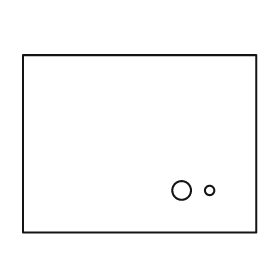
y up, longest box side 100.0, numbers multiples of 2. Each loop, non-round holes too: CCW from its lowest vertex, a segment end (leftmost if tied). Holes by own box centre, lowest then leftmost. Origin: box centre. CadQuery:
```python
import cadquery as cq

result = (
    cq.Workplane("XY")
    .moveTo(-50.0, -38.0)
    .lineTo(50.0, -38.0)
    .lineTo(50.0, 38.0)
    .lineTo(-50.0, 38.0)
    .close()
    .moveTo(18.0, -20.0)
    .circle(4.0)
    .moveTo(30.0, -20.0)
    .circle(2.0)
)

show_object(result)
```